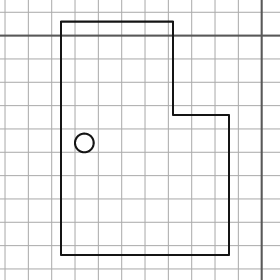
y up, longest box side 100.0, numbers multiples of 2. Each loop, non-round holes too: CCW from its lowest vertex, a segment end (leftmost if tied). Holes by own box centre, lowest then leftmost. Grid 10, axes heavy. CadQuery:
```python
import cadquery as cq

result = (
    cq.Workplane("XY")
    .moveTo(-86.0, -94.0)
    .lineTo(-14.0, -94.0)
    .lineTo(-14.0, -34.0)
    .lineTo(-38.0, -34.0)
    .lineTo(-38.0, 6.0)
    .lineTo(-86.0, 6.0)
    .close()
    .moveTo(-76.0, -46.0)
    .circle(4.0)
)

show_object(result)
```